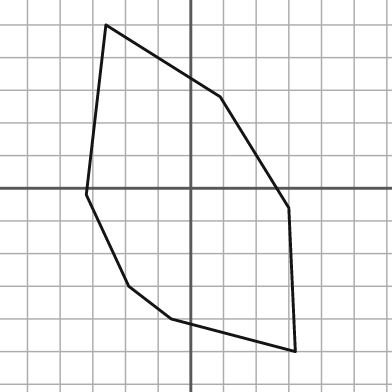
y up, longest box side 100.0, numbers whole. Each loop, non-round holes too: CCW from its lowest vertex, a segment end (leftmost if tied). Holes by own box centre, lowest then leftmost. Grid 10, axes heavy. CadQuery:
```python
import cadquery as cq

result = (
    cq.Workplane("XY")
    .moveTo(32.0, -50.0)
    .lineTo(30.0, -6.0)
    .lineTo(9.0, 28.0)
    .lineTo(-26.0, 50.0)
    .lineTo(-32.0, -2.0)
    .lineTo(-19.0, -30.0)
    .lineTo(-6.0, -40.0)
    .close()
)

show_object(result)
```